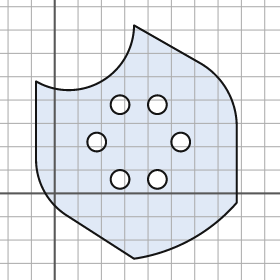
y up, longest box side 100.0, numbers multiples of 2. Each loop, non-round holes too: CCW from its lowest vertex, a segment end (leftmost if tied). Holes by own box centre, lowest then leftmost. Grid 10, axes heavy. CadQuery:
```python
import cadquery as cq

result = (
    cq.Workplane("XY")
    .moveTo(34.0, -28.0)
    .threePointArc((58.0, -20.0), (78.0, -4.0))
    .lineTo(78.0, 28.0)
    .threePointArc((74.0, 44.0), (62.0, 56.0))
    .lineTo(34.0, 72.0)
    .threePointArc((20.0, 48.0), (-8.0, 48.0))
    .lineTo(-8.0, 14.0)
    .threePointArc((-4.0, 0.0), (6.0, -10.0))
    .close()
    .moveTo(28.0, 6.0)
    .circle(4.0)
    .moveTo(44.0, 6.0)
    .circle(4.0)
    .moveTo(18.0, 22.0)
    .circle(4.0)
    .moveTo(54.0, 22.0)
    .circle(4.0)
    .moveTo(28.0, 38.0)
    .circle(4.0)
    .moveTo(44.0, 38.0)
    .circle(4.0)
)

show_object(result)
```